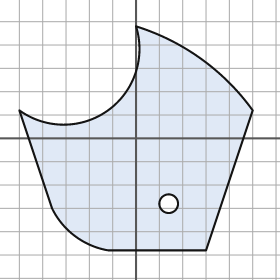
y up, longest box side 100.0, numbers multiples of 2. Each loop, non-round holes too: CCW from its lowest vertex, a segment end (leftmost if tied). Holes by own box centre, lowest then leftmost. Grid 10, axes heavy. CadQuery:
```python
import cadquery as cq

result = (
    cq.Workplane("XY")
    .moveTo(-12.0, -48.0)
    .lineTo(30.0, -48.0)
    .lineTo(50.0, 12.0)
    .threePointArc((28.0, 34.0), (0.0, 48.0))
    .threePointArc((-12.0, 12.0), (-50.0, 12.0))
    .lineTo(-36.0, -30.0)
    .threePointArc((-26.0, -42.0), (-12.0, -48.0))
    .close()
    .moveTo(14.0, -28.0)
    .circle(4.0)
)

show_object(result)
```